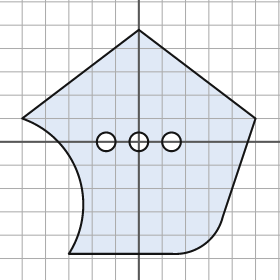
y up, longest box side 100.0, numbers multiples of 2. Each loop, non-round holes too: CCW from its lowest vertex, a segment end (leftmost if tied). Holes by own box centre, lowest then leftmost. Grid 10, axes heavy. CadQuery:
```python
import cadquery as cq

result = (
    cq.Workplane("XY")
    .moveTo(-30.0, -48.0)
    .lineTo(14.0, -48.0)
    .threePointArc((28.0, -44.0), (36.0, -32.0))
    .lineTo(50.0, 10.0)
    .lineTo(0.0, 48.0)
    .lineTo(-50.0, 10.0)
    .threePointArc((-26.0, -14.0), (-30.0, -48.0))
    .close()
    .moveTo(-14.0, 0.0)
    .circle(4.0)
    .moveTo(0.0, 0.0)
    .circle(4.0)
    .moveTo(14.0, 0.0)
    .circle(4.0)
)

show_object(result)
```